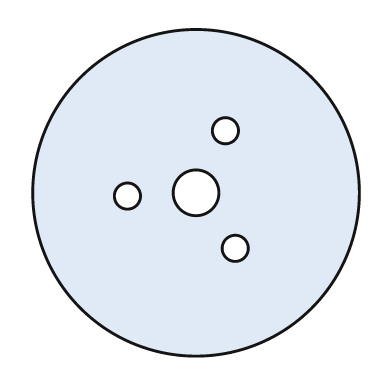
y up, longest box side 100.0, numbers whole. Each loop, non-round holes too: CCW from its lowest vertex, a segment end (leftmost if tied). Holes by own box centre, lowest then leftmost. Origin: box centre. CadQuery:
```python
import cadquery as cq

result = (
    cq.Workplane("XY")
    .moveTo(0.0, 0.0)
    .circle(50.0)
    .moveTo(12.0, -17.0)
    .circle(4.0)
    .moveTo(-21.0, -1.0)
    .circle(4.0)
    .moveTo(0.0, 0.0)
    .circle(7.0)
    .moveTo(9.0, 19.0)
    .circle(4.0)
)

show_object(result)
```